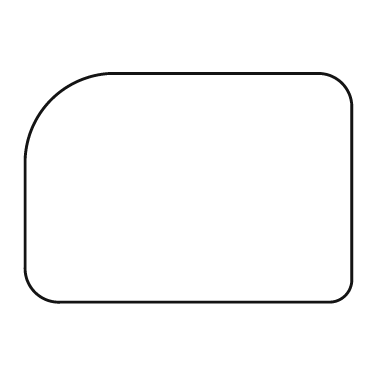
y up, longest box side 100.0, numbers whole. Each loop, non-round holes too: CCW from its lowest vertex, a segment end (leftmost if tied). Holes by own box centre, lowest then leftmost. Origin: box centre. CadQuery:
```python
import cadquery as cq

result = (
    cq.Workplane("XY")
    .moveTo(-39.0, -35.0)
    .lineTo(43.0, -35.0)
    .threePointArc((48.0, -33.0), (50.0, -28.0))
    .lineTo(50.0, 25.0)
    .threePointArc((47.0, 32.0), (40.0, 35.0))
    .lineTo(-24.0, 35.0)
    .threePointArc((-42.0, 27.0), (-50.0, 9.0))
    .lineTo(-50.0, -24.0)
    .threePointArc((-47.0, -32.0), (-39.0, -35.0))
    .close()
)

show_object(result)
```